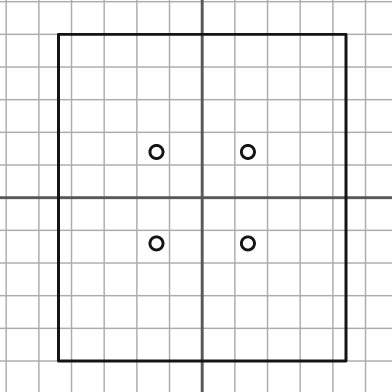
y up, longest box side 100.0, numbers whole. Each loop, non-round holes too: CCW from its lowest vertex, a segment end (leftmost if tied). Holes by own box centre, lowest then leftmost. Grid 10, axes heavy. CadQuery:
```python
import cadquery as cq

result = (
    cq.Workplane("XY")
    .moveTo(-44.0, -50.0)
    .lineTo(44.0, -50.0)
    .lineTo(44.0, 50.0)
    .lineTo(-44.0, 50.0)
    .close()
    .moveTo(-14.0, -14.0)
    .circle(2.0)
    .moveTo(14.0, -14.0)
    .circle(2.0)
    .moveTo(-14.0, 14.0)
    .circle(2.0)
    .moveTo(14.0, 14.0)
    .circle(2.0)
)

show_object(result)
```